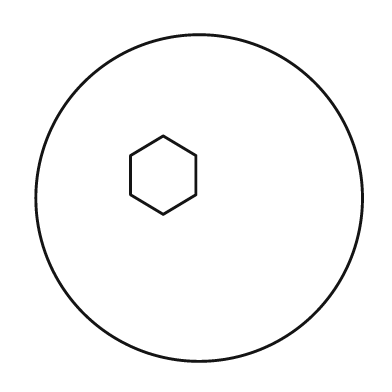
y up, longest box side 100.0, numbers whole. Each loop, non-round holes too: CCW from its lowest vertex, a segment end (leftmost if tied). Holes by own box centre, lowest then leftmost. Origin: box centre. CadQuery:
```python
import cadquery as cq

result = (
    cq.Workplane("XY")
    .moveTo(0.0, 0.0)
    .circle(50.0)
    .moveTo(-11.0, -5.0)
    .lineTo(-1.0, 1.0)
    .lineTo(-1.0, 13.0)
    .lineTo(-11.0, 19.0)
    .lineTo(-21.0, 13.0)
    .lineTo(-21.0, 1.0)
    .close()
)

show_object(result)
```